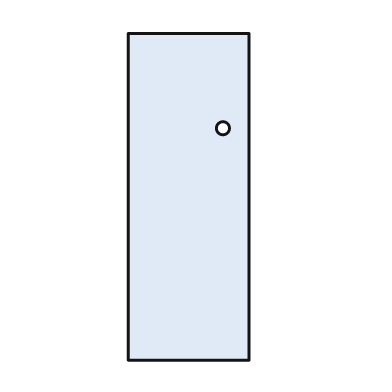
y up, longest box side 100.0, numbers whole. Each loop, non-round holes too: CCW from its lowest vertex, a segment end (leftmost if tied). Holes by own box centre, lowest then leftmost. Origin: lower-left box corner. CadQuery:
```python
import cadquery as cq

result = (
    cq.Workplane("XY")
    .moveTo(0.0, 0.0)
    .lineTo(37.0, 0.0)
    .lineTo(37.0, 100.0)
    .lineTo(0.0, 100.0)
    .close()
    .moveTo(29.0, 71.0)
    .circle(2.0)
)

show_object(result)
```